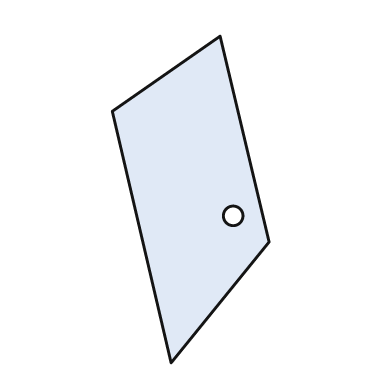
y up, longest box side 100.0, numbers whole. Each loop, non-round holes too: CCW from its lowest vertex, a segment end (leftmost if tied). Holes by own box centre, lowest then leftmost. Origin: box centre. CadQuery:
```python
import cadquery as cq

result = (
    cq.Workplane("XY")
    .moveTo(-6.0, -50.0)
    .lineTo(24.0, -13.0)
    .lineTo(9.0, 50.0)
    .lineTo(-24.0, 27.0)
    .close()
    .moveTo(13.0, -5.0)
    .circle(3.0)
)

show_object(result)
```